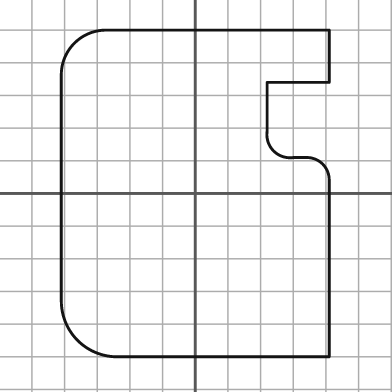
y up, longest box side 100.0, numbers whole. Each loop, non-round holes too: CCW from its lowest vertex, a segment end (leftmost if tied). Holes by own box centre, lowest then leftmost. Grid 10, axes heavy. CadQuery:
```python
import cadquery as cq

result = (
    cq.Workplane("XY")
    .moveTo(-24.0, -50.0)
    .lineTo(41.0, -50.0)
    .lineTo(41.0, 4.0)
    .threePointArc((39.0, 9.0), (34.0, 11.0))
    .lineTo(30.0, 11.0)
    .threePointArc((24.0, 13.0), (22.0, 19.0))
    .lineTo(22.0, 34.0)
    .lineTo(41.0, 34.0)
    .lineTo(41.0, 50.0)
    .lineTo(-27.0, 50.0)
    .threePointArc((-37.0, 46.0), (-41.0, 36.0))
    .lineTo(-41.0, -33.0)
    .threePointArc((-36.0, -45.0), (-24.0, -50.0))
    .close()
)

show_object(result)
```